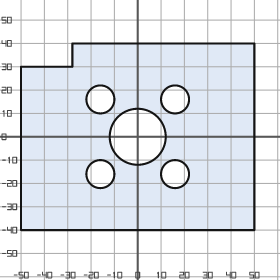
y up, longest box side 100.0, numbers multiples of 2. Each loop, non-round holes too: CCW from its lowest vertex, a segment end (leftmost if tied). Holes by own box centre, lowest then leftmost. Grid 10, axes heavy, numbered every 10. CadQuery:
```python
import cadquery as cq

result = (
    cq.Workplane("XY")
    .moveTo(-50.0, -40.0)
    .lineTo(50.0, -40.0)
    .lineTo(50.0, 40.0)
    .lineTo(-28.0, 40.0)
    .lineTo(-28.0, 30.0)
    .lineTo(-50.0, 30.0)
    .close()
    .moveTo(-16.0, -16.0)
    .circle(6.0)
    .moveTo(16.0, -16.0)
    .circle(6.0)
    .moveTo(0.0, 0.0)
    .circle(12.0)
    .moveTo(-16.0, 16.0)
    .circle(6.0)
    .moveTo(16.0, 16.0)
    .circle(6.0)
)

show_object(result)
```